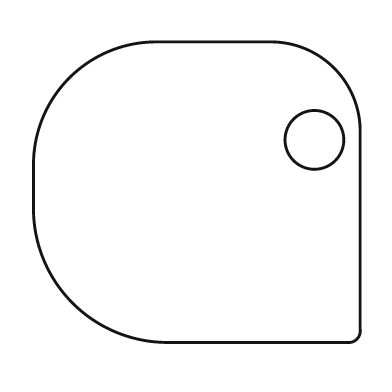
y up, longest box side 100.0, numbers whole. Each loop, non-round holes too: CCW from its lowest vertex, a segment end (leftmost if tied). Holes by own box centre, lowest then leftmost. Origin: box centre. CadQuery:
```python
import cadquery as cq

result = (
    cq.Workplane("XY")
    .moveTo(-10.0, -46.0)
    .lineTo(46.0, -46.0)
    .threePointArc((49.0, -45.0), (50.0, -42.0))
    .lineTo(50.0, 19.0)
    .threePointArc((42.0, 38.0), (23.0, 46.0))
    .lineTo(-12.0, 46.0)
    .threePointArc((-39.0, 35.0), (-50.0, 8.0))
    .lineTo(-50.0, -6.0)
    .threePointArc((-38.0, -34.0), (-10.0, -46.0))
    .close()
    .moveTo(36.0, 16.0)
    .circle(9.0)
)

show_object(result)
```